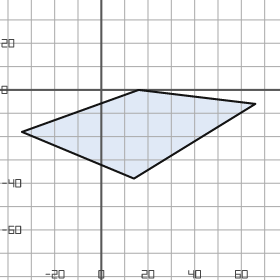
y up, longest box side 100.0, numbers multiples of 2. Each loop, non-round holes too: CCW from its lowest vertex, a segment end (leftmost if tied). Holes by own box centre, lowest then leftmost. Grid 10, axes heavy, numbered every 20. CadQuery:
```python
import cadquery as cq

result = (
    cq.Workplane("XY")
    .moveTo(14.0, -38.0)
    .lineTo(66.0, -6.0)
    .lineTo(16.0, 0.0)
    .lineTo(-34.0, -18.0)
    .close()
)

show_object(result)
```